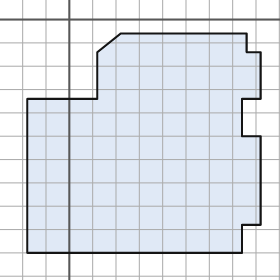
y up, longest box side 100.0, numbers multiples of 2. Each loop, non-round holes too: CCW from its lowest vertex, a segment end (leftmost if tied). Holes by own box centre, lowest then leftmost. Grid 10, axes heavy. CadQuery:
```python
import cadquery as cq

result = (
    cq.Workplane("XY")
    .moveTo(-18.0, -100.0)
    .lineTo(74.0, -100.0)
    .lineTo(74.0, -88.0)
    .lineTo(82.0, -88.0)
    .lineTo(82.0, -50.0)
    .lineTo(74.0, -50.0)
    .lineTo(74.0, -34.0)
    .lineTo(82.0, -34.0)
    .lineTo(82.0, -14.0)
    .lineTo(76.0, -14.0)
    .lineTo(76.0, -6.0)
    .lineTo(22.0, -6.0)
    .lineTo(12.0, -14.0)
    .lineTo(12.0, -34.0)
    .lineTo(-18.0, -34.0)
    .close()
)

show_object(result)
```